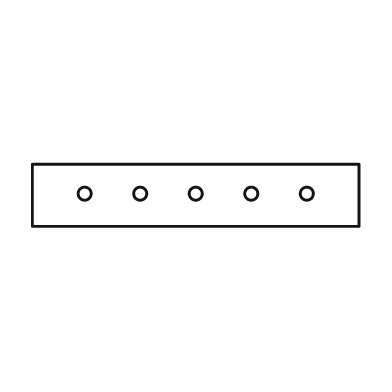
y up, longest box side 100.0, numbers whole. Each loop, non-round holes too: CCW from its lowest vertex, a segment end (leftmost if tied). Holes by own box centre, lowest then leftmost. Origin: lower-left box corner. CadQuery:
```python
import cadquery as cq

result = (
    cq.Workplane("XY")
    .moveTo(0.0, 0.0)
    .lineTo(100.0, 0.0)
    .lineTo(100.0, 19.0)
    .lineTo(0.0, 19.0)
    .close()
    .moveTo(16.0, 10.0)
    .circle(2.0)
    .moveTo(33.0, 10.0)
    .circle(2.0)
    .moveTo(50.0, 10.0)
    .circle(2.0)
    .moveTo(67.0, 10.0)
    .circle(2.0)
    .moveTo(84.0, 10.0)
    .circle(2.0)
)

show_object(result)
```